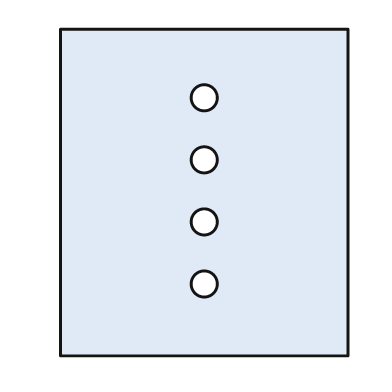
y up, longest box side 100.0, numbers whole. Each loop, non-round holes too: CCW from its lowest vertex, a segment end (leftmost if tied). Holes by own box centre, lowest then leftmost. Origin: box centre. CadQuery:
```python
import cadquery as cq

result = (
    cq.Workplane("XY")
    .moveTo(-44.0, -50.0)
    .lineTo(44.0, -50.0)
    .lineTo(44.0, 50.0)
    .lineTo(-44.0, 50.0)
    .close()
    .moveTo(0.0, -28.0)
    .circle(4.0)
    .moveTo(0.0, -9.0)
    .circle(4.0)
    .moveTo(0.0, 10.0)
    .circle(4.0)
    .moveTo(0.0, 29.0)
    .circle(4.0)
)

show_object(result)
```